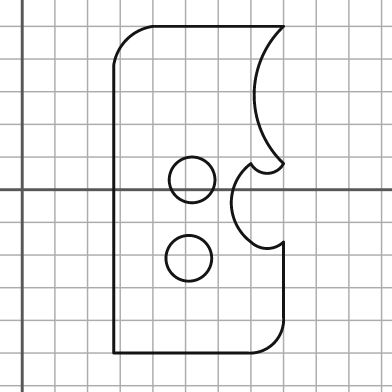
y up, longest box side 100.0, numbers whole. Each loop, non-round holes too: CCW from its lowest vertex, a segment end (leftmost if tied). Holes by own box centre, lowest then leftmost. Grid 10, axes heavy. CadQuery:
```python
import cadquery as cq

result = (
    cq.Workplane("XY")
    .moveTo(28.0, -50.0)
    .lineTo(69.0, -50.0)
    .threePointArc((77.0, -47.0), (80.0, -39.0))
    .lineTo(80.0, -16.0)
    .threePointArc((75.0, -18.0), (70.0, -16.0))
    .threePointArc((64.0, -4.0), (70.0, 8.0))
    .threePointArc((75.0, 5.0), (80.0, 8.0))
    .threePointArc((71.0, 29.0), (80.0, 50.0))
    .lineTo(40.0, 50.0)
    .threePointArc((32.0, 46.0), (28.0, 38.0))
    .close()
    .moveTo(51.0, -21.0)
    .circle(7.0)
    .moveTo(52.0, 3.0)
    .circle(7.0)
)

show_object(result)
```